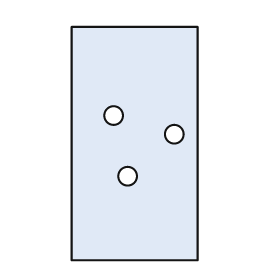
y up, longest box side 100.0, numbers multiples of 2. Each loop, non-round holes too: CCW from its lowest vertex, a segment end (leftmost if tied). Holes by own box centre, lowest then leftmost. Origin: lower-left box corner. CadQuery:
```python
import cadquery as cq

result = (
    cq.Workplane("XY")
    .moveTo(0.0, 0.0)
    .lineTo(54.0, 0.0)
    .lineTo(54.0, 100.0)
    .lineTo(0.0, 100.0)
    .close()
    .moveTo(24.0, 36.0)
    .circle(4.0)
    .moveTo(44.0, 54.0)
    .circle(4.0)
    .moveTo(18.0, 62.0)
    .circle(4.0)
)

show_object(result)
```